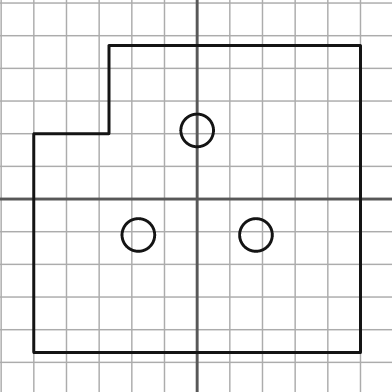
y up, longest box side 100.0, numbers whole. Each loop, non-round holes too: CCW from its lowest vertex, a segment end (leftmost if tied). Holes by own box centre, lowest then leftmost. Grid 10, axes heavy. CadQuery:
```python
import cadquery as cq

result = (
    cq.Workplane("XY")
    .moveTo(-50.0, -47.0)
    .lineTo(50.0, -47.0)
    .lineTo(50.0, 47.0)
    .lineTo(-27.0, 47.0)
    .lineTo(-27.0, 20.0)
    .lineTo(-50.0, 20.0)
    .close()
    .moveTo(-18.0, -11.0)
    .circle(5.0)
    .moveTo(18.0, -11.0)
    .circle(5.0)
    .moveTo(0.0, 21.0)
    .circle(5.0)
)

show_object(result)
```